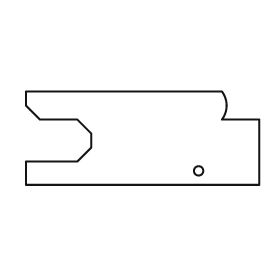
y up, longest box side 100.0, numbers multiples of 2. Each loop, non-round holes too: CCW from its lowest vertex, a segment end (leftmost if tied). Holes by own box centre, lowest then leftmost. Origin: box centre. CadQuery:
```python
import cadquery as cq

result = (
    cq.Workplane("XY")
    .moveTo(-50.0, -20.0)
    .lineTo(50.0, -20.0)
    .lineTo(50.0, 8.0)
    .lineTo(34.0, 8.0)
    .threePointArc((36.0, 14.0), (34.0, 20.0))
    .lineTo(-50.0, 20.0)
    .lineTo(-50.0, 14.0)
    .lineTo(-44.0, 8.0)
    .lineTo(-28.0, 8.0)
    .lineTo(-22.0, 2.0)
    .lineTo(-22.0, -4.0)
    .lineTo(-28.0, -10.0)
    .lineTo(-50.0, -10.0)
    .close()
    .moveTo(24.0, -14.0)
    .circle(2.0)
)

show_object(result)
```